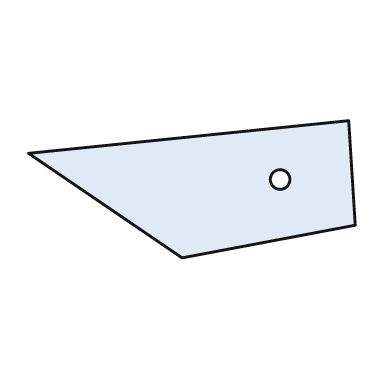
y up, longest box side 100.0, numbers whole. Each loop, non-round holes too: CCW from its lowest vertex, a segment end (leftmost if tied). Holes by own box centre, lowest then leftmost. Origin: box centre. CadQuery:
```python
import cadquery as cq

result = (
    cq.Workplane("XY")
    .moveTo(-3.0, -21.0)
    .lineTo(50.0, -11.0)
    .lineTo(48.0, 21.0)
    .lineTo(-50.0, 11.0)
    .close()
    .moveTo(27.0, 3.0)
    .circle(3.0)
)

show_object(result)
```